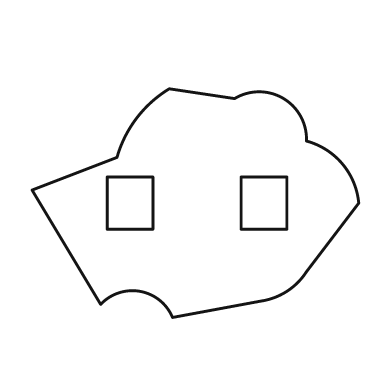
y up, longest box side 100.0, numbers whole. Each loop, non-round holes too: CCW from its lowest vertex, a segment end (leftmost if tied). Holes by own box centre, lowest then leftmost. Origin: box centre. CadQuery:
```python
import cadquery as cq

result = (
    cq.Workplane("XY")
    .moveTo(-7.0, -35.0)
    .lineTo(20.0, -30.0)
    .threePointArc((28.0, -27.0), (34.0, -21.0))
    .lineTo(50.0, 0.0)
    .threePointArc((45.0, 12.0), (34.0, 19.0))
    .threePointArc((27.0, 32.0), (12.0, 32.0))
    .lineTo(-8.0, 35.0)
    .threePointArc((-18.0, 26.0), (-24.0, 14.0))
    .lineTo(-50.0, 4.0)
    .lineTo(-29.0, -31.0)
    .threePointArc((-17.0, -27.0), (-7.0, -35.0))
    .close()
    .moveTo(-27.0, -8.0)
    .lineTo(-13.0, -8.0)
    .lineTo(-13.0, 8.0)
    .lineTo(-27.0, 8.0)
    .close()
    .moveTo(14.0, -8.0)
    .lineTo(28.0, -8.0)
    .lineTo(28.0, 8.0)
    .lineTo(14.0, 8.0)
    .close()
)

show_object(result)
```